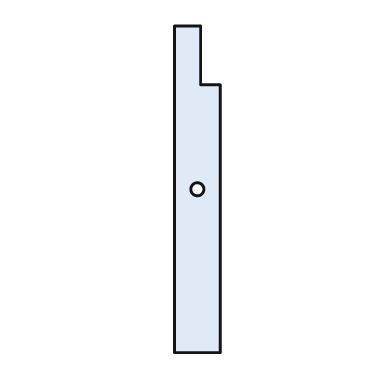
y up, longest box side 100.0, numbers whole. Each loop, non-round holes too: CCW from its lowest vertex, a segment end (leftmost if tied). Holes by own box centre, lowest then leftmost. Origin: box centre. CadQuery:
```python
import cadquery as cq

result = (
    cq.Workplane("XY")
    .moveTo(-7.0, -50.0)
    .lineTo(7.0, -50.0)
    .lineTo(7.0, 32.0)
    .lineTo(1.0, 32.0)
    .lineTo(1.0, 50.0)
    .lineTo(-7.0, 50.0)
    .close()
    .moveTo(0.0, 0.0)
    .circle(2.0)
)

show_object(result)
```